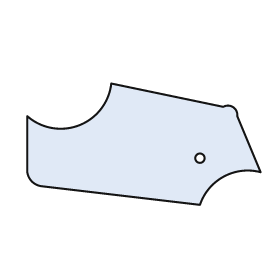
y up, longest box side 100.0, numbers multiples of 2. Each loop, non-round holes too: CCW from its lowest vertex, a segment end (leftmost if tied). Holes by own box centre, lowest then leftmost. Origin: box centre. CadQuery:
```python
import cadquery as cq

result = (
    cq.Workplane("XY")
    .moveTo(24.0, -26.0)
    .threePointArc((34.0, -14.0), (50.0, -12.0))
    .lineTo(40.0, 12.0)
    .threePointArc((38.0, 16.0), (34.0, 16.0))
    .lineTo(-14.0, 26.0)
    .threePointArc((-28.0, 8.0), (-50.0, 12.0))
    .lineTo(-50.0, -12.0)
    .threePointArc((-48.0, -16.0), (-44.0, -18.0))
    .close()
    .moveTo(24.0, -6.0)
    .circle(2.0)
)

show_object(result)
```